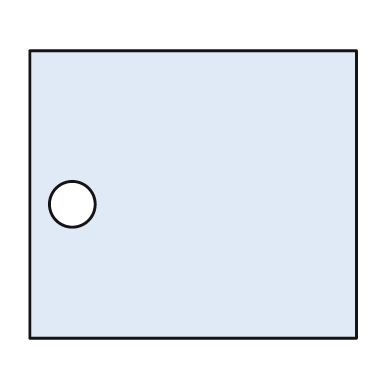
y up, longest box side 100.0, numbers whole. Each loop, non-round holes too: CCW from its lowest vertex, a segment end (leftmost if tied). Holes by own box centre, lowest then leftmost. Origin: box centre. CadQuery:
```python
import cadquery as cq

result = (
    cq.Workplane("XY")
    .moveTo(-50.0, -44.0)
    .lineTo(50.0, -44.0)
    .lineTo(50.0, 44.0)
    .lineTo(-50.0, 44.0)
    .close()
    .moveTo(-37.0, -3.0)
    .circle(7.0)
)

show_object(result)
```